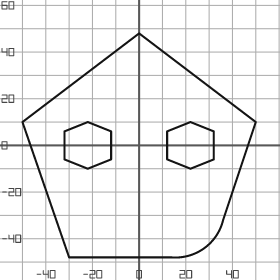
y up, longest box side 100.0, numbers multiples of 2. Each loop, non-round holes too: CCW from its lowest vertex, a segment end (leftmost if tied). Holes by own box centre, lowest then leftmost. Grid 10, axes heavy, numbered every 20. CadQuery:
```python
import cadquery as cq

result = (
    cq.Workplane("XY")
    .moveTo(-30.0, -48.0)
    .lineTo(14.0, -48.0)
    .threePointArc((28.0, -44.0), (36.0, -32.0))
    .lineTo(50.0, 10.0)
    .lineTo(0.0, 48.0)
    .lineTo(-50.0, 10.0)
    .close()
    .moveTo(-22.0, -10.0)
    .lineTo(-12.0, -6.0)
    .lineTo(-12.0, 6.0)
    .lineTo(-22.0, 10.0)
    .lineTo(-32.0, 6.0)
    .lineTo(-32.0, -6.0)
    .close()
    .moveTo(22.0, -10.0)
    .lineTo(32.0, -6.0)
    .lineTo(32.0, 6.0)
    .lineTo(22.0, 10.0)
    .lineTo(12.0, 6.0)
    .lineTo(12.0, -6.0)
    .close()
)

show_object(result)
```